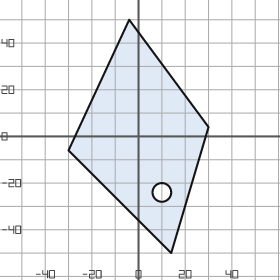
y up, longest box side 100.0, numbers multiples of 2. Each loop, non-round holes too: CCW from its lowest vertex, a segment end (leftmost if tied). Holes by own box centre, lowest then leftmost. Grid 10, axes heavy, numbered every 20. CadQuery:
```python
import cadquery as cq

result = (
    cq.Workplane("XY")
    .moveTo(14.0, -50.0)
    .lineTo(30.0, 4.0)
    .lineTo(-4.0, 50.0)
    .lineTo(-30.0, -6.0)
    .close()
    .moveTo(10.0, -24.0)
    .circle(4.0)
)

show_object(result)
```